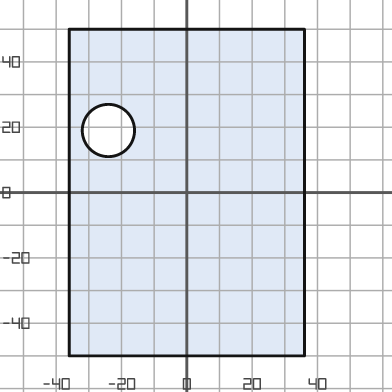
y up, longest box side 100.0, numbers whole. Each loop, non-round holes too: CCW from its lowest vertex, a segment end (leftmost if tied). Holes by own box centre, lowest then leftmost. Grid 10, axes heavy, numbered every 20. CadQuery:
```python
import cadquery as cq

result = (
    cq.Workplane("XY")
    .moveTo(-36.0, -50.0)
    .lineTo(36.0, -50.0)
    .lineTo(36.0, 50.0)
    .lineTo(-36.0, 50.0)
    .close()
    .moveTo(-24.0, 19.0)
    .circle(8.0)
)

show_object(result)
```